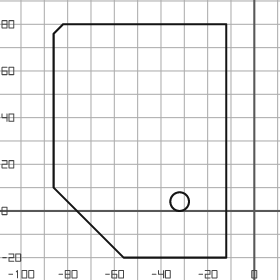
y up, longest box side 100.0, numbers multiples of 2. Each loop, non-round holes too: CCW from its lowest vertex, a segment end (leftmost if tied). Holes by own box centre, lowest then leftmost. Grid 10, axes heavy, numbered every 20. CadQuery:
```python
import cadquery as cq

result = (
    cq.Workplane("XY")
    .moveTo(-56.0, -20.0)
    .lineTo(-12.0, -20.0)
    .lineTo(-12.0, 80.0)
    .lineTo(-82.0, 80.0)
    .lineTo(-86.0, 76.0)
    .lineTo(-86.0, 10.0)
    .close()
    .moveTo(-32.0, 4.0)
    .circle(4.0)
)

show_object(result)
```